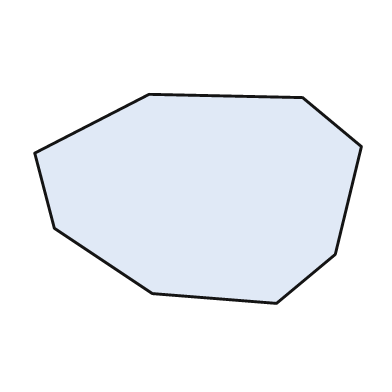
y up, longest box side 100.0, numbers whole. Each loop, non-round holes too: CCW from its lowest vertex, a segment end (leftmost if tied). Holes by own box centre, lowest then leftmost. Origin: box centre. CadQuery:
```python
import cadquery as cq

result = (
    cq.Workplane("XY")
    .moveTo(24.0, -32.0)
    .lineTo(42.0, -17.0)
    .lineTo(50.0, 16.0)
    .lineTo(32.0, 31.0)
    .lineTo(-15.0, 32.0)
    .lineTo(-50.0, 14.0)
    .lineTo(-44.0, -9.0)
    .lineTo(-14.0, -29.0)
    .close()
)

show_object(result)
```